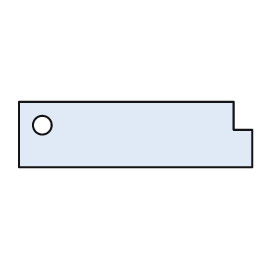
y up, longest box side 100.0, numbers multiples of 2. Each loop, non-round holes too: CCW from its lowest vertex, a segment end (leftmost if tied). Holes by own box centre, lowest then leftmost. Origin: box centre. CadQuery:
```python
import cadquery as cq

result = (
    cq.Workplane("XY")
    .moveTo(-50.0, -14.0)
    .lineTo(50.0, -14.0)
    .lineTo(50.0, 2.0)
    .lineTo(42.0, 2.0)
    .lineTo(42.0, 14.0)
    .lineTo(-50.0, 14.0)
    .close()
    .moveTo(-40.0, 4.0)
    .circle(4.0)
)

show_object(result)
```